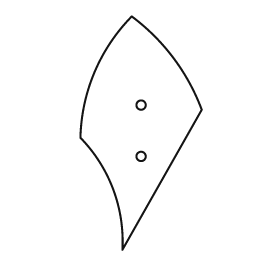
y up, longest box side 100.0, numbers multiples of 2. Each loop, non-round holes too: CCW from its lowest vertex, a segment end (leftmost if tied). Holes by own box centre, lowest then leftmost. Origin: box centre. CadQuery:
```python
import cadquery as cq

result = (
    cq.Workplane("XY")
    .moveTo(-8.0, -50.0)
    .lineTo(26.0, 10.0)
    .threePointArc((14.0, 32.0), (-4.0, 50.0))
    .threePointArc((-20.0, 26.0), (-26.0, -2.0))
    .threePointArc((-12.0, -24.0), (-8.0, -50.0))
    .close()
    .moveTo(0.0, -10.0)
    .circle(2.0)
    .moveTo(0.0, 12.0)
    .circle(2.0)
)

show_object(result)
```